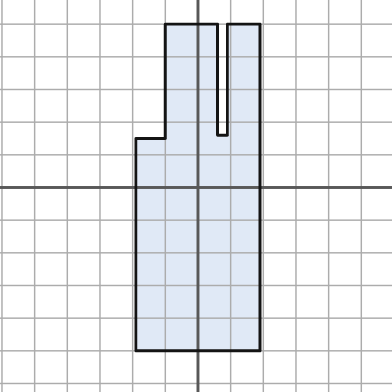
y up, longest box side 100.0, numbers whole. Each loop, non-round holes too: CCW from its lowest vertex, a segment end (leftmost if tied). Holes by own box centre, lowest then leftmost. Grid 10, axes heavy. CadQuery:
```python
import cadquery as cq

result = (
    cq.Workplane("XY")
    .moveTo(-19.0, -50.0)
    .lineTo(19.0, -50.0)
    .lineTo(19.0, 50.0)
    .lineTo(9.0, 50.0)
    .lineTo(9.0, 16.0)
    .lineTo(6.0, 16.0)
    .lineTo(6.0, 50.0)
    .lineTo(-10.0, 50.0)
    .lineTo(-10.0, 15.0)
    .lineTo(-19.0, 15.0)
    .close()
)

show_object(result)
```